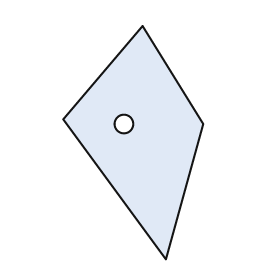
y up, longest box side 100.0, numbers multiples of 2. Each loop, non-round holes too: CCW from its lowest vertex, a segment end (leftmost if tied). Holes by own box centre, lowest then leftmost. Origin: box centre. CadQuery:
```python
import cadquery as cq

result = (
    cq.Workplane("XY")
    .moveTo(14.0, -50.0)
    .lineTo(30.0, 8.0)
    .lineTo(4.0, 50.0)
    .lineTo(-30.0, 10.0)
    .close()
    .moveTo(-4.0, 8.0)
    .circle(4.0)
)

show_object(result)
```